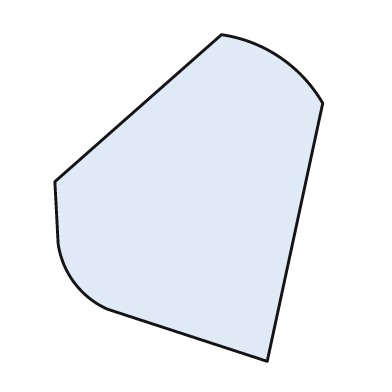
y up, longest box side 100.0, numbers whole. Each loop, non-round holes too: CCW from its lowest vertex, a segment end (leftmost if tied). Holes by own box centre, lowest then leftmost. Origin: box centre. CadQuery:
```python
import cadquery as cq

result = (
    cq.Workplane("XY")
    .moveTo(24.0, -50.0)
    .lineTo(41.0, 29.0)
    .threePointArc((28.0, 43.0), (10.0, 50.0))
    .lineTo(-41.0, 5.0)
    .lineTo(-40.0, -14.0)
    .threePointArc((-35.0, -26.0), (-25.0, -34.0))
    .close()
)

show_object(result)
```